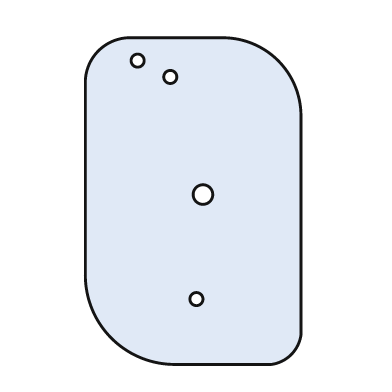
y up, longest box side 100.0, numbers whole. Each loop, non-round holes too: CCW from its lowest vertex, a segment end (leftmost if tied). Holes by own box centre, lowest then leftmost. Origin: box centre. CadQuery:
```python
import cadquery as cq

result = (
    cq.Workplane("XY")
    .moveTo(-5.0, -50.0)
    .lineTo(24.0, -50.0)
    .threePointArc((30.0, -47.0), (33.0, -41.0))
    .lineTo(33.0, 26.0)
    .threePointArc((26.0, 43.0), (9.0, 50.0))
    .lineTo(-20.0, 50.0)
    .threePointArc((-29.0, 46.0), (-33.0, 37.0))
    .lineTo(-33.0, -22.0)
    .threePointArc((-25.0, -42.0), (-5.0, -50.0))
    .close()
    .moveTo(1.0, -30.0)
    .circle(2.0)
    .moveTo(3.0, 2.0)
    .circle(3.0)
    .moveTo(-7.0, 38.0)
    .circle(2.0)
    .moveTo(-17.0, 43.0)
    .circle(2.0)
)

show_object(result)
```